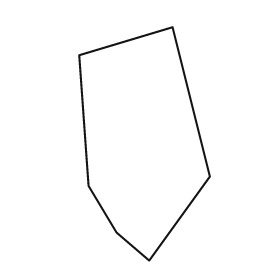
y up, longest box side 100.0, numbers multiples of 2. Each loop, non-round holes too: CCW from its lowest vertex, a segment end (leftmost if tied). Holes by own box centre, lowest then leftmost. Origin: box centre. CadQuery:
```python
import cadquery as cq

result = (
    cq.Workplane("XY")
    .moveTo(2.0, -50.0)
    .lineTo(28.0, -14.0)
    .lineTo(12.0, 50.0)
    .lineTo(-28.0, 38.0)
    .lineTo(-24.0, -18.0)
    .lineTo(-12.0, -38.0)
    .close()
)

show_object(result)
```